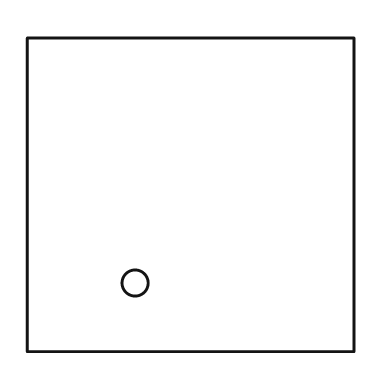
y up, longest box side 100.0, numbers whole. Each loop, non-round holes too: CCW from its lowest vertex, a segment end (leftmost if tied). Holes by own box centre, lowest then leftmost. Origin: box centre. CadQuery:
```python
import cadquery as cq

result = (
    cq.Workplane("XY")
    .moveTo(-50.0, -48.0)
    .lineTo(50.0, -48.0)
    .lineTo(50.0, 48.0)
    .lineTo(-50.0, 48.0)
    .close()
    .moveTo(-17.0, -27.0)
    .circle(4.0)
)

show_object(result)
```